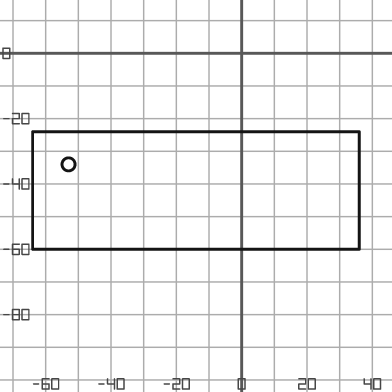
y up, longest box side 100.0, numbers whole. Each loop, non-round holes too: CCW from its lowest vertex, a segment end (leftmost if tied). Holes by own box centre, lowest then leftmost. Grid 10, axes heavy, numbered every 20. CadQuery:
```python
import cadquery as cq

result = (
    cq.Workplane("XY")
    .moveTo(-64.0, -60.0)
    .lineTo(36.0, -60.0)
    .lineTo(36.0, -24.0)
    .lineTo(-64.0, -24.0)
    .close()
    .moveTo(-53.0, -34.0)
    .circle(2.0)
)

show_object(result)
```